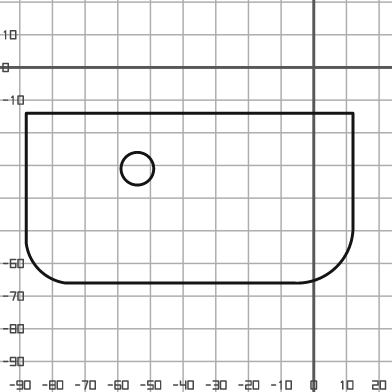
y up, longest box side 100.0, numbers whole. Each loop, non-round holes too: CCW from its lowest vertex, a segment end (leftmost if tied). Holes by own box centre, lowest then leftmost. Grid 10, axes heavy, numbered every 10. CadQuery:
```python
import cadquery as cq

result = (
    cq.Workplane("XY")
    .moveTo(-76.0, -66.0)
    .lineTo(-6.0, -66.0)
    .threePointArc((7.0, -61.0), (12.0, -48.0))
    .lineTo(12.0, -14.0)
    .lineTo(-88.0, -14.0)
    .lineTo(-88.0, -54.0)
    .threePointArc((-84.0, -62.0), (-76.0, -66.0))
    .close()
    .moveTo(-54.0, -31.0)
    .circle(5.0)
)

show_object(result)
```